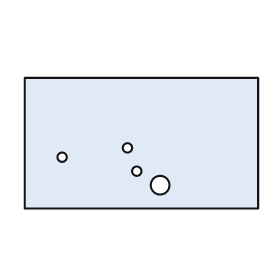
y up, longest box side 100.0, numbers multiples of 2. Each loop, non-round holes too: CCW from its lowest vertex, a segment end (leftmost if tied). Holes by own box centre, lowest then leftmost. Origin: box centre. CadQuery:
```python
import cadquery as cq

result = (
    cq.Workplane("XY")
    .moveTo(-50.0, -28.0)
    .lineTo(50.0, -28.0)
    .lineTo(50.0, 28.0)
    .lineTo(-50.0, 28.0)
    .close()
    .moveTo(8.0, -18.0)
    .circle(4.0)
    .moveTo(-2.0, -12.0)
    .circle(2.0)
    .moveTo(-34.0, -6.0)
    .circle(2.0)
    .moveTo(-6.0, -2.0)
    .circle(2.0)
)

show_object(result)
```